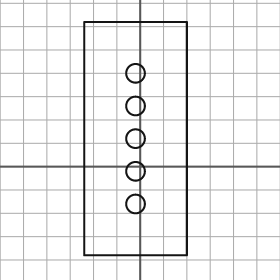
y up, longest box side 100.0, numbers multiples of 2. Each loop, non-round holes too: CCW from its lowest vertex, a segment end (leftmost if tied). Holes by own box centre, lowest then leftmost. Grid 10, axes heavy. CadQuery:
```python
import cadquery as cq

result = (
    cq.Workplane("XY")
    .moveTo(-24.0, -38.0)
    .lineTo(20.0, -38.0)
    .lineTo(20.0, 62.0)
    .lineTo(-24.0, 62.0)
    .close()
    .moveTo(-2.0, -16.0)
    .circle(4.0)
    .moveTo(-2.0, -2.0)
    .circle(4.0)
    .moveTo(-2.0, 12.0)
    .circle(4.0)
    .moveTo(-2.0, 26.0)
    .circle(4.0)
    .moveTo(-2.0, 40.0)
    .circle(4.0)
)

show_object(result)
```